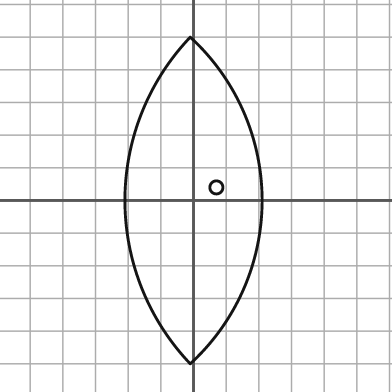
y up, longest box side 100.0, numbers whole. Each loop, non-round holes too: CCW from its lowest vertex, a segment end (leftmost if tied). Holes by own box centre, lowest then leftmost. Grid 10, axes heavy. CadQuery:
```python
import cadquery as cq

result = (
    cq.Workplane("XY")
    .moveTo(-1.0, -50.0)
    .threePointArc((21.0, 0.0), (-1.0, 50.0))
    .threePointArc((-21.0, 0.0), (-1.0, -50.0))
    .close()
    .moveTo(7.0, 4.0)
    .circle(2.0)
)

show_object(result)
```